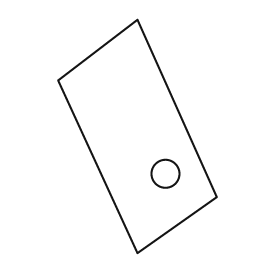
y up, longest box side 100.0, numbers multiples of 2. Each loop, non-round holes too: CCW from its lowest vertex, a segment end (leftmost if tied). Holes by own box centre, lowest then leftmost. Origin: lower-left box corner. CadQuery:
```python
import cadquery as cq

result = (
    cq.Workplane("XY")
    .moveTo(34.0, 0.0)
    .lineTo(68.0, 24.0)
    .lineTo(34.0, 100.0)
    .lineTo(0.0, 74.0)
    .close()
    .moveTo(46.0, 34.0)
    .circle(6.0)
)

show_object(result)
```